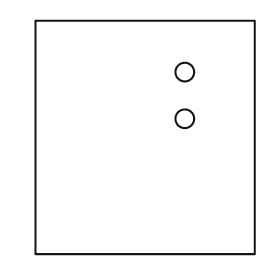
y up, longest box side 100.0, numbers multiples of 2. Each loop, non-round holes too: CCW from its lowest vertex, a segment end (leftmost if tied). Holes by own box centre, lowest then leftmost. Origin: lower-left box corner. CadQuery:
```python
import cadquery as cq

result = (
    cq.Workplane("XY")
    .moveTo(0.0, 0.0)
    .lineTo(94.0, 0.0)
    .lineTo(94.0, 100.0)
    .lineTo(0.0, 100.0)
    .close()
    .moveTo(64.0, 58.0)
    .circle(4.0)
    .moveTo(64.0, 78.0)
    .circle(4.0)
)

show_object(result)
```